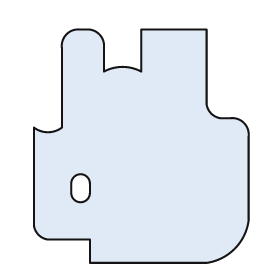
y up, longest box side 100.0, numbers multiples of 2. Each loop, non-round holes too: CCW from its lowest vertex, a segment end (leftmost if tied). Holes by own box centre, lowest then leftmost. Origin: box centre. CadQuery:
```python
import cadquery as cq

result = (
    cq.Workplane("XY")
    .moveTo(-22.0, -50.0)
    .lineTo(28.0, -50.0)
    .threePointArc((40.0, -44.0), (46.0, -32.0))
    .lineTo(46.0, 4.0)
    .threePointArc((44.0, 10.0), (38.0, 12.0))
    .lineTo(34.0, 12.0)
    .threePointArc((30.0, 14.0), (28.0, 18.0))
    .lineTo(28.0, 50.0)
    .lineTo(0.0, 50.0)
    .lineTo(0.0, 32.0)
    .threePointArc((-8.0, 34.0), (-16.0, 32.0))
    .lineTo(-16.0, 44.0)
    .threePointArc((-18.0, 48.0), (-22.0, 50.0))
    .lineTo(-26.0, 50.0)
    .threePointArc((-32.0, 48.0), (-34.0, 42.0))
    .lineTo(-34.0, 8.0)
    .threePointArc((-40.0, 6.0), (-46.0, 8.0))
    .lineTo(-46.0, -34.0)
    .threePointArc((-44.0, -38.0), (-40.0, -40.0))
    .lineTo(-22.0, -40.0)
    .close()
    .moveTo(-30.0, -20.0)
    .threePointArc((-26.0, -24.0), (-22.0, -20.0))
    .lineTo(-22.0, -16.0)
    .threePointArc((-26.0, -12.0), (-30.0, -16.0))
    .close()
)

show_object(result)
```